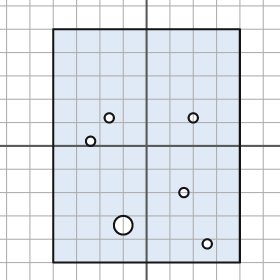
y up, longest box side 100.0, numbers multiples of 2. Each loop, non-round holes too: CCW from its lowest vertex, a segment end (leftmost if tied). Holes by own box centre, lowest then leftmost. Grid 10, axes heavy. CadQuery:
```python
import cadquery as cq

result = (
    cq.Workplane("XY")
    .moveTo(-40.0, -50.0)
    .lineTo(40.0, -50.0)
    .lineTo(40.0, 50.0)
    .lineTo(-40.0, 50.0)
    .close()
    .moveTo(26.0, -42.0)
    .circle(2.0)
    .moveTo(-10.0, -34.0)
    .circle(4.0)
    .moveTo(16.0, -20.0)
    .circle(2.0)
    .moveTo(-24.0, 2.0)
    .circle(2.0)
    .moveTo(-16.0, 12.0)
    .circle(2.0)
    .moveTo(20.0, 12.0)
    .circle(2.0)
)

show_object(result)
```